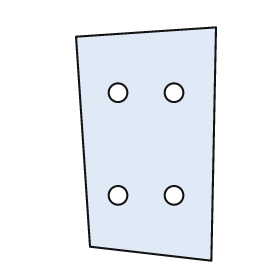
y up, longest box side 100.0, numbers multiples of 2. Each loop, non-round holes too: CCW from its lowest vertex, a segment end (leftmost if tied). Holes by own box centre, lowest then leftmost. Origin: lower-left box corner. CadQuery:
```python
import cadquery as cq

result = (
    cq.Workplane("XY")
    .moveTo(58.0, 0.0)
    .lineTo(60.0, 100.0)
    .lineTo(0.0, 96.0)
    .lineTo(6.0, 6.0)
    .close()
    .moveTo(18.0, 28.0)
    .circle(4.0)
    .moveTo(42.0, 28.0)
    .circle(4.0)
    .moveTo(18.0, 72.0)
    .circle(4.0)
    .moveTo(42.0, 72.0)
    .circle(4.0)
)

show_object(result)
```